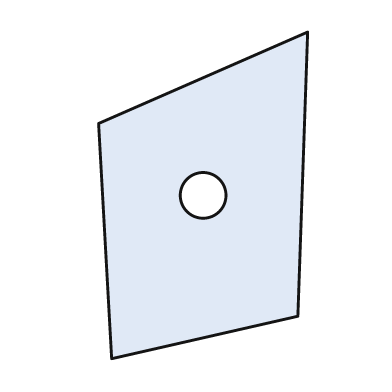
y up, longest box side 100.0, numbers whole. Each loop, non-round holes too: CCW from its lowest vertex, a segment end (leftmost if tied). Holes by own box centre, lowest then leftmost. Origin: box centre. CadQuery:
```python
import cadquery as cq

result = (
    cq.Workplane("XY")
    .moveTo(-28.0, -50.0)
    .lineTo(29.0, -37.0)
    .lineTo(32.0, 50.0)
    .lineTo(-32.0, 22.0)
    .close()
    .moveTo(0.0, 0.0)
    .circle(7.0)
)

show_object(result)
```